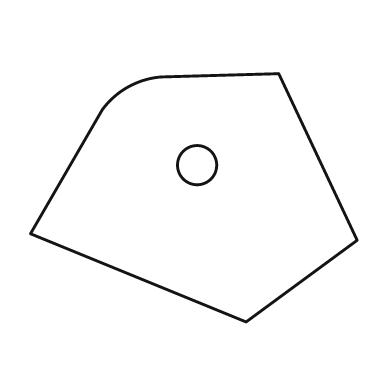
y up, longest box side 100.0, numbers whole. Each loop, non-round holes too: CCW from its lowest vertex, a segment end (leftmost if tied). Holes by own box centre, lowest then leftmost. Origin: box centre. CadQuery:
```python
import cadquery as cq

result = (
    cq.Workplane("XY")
    .moveTo(16.0, -38.0)
    .lineTo(50.0, -13.0)
    .lineTo(26.0, 38.0)
    .lineTo(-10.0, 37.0)
    .threePointArc((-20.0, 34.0), (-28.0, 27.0))
    .lineTo(-50.0, -11.0)
    .close()
    .moveTo(1.0, 10.0)
    .circle(6.0)
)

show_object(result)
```